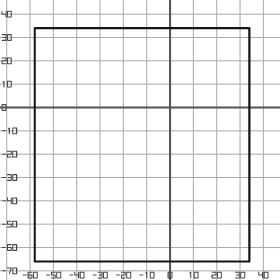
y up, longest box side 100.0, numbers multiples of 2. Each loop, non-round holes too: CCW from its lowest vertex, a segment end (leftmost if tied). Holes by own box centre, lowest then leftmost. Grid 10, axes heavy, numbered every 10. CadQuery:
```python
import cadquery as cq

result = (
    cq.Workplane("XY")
    .moveTo(-58.0, -66.0)
    .lineTo(34.0, -66.0)
    .lineTo(34.0, 34.0)
    .lineTo(-58.0, 34.0)
    .close()
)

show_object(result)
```